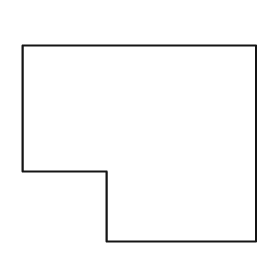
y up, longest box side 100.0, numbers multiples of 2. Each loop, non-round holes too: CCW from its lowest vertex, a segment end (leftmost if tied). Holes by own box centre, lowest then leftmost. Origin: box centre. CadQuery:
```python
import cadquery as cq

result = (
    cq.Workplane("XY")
    .moveTo(-14.0, -42.0)
    .lineTo(50.0, -42.0)
    .lineTo(50.0, 42.0)
    .lineTo(-50.0, 42.0)
    .lineTo(-50.0, -12.0)
    .lineTo(-14.0, -12.0)
    .close()
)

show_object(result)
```